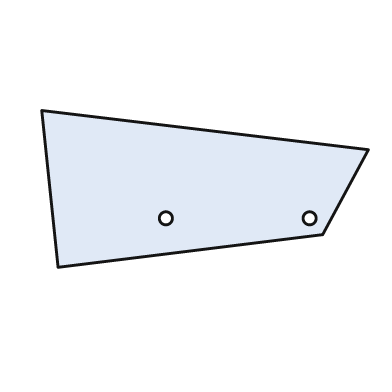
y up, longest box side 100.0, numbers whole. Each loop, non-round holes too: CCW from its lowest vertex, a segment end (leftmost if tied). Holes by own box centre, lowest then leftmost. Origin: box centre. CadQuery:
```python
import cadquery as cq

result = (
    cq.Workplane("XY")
    .moveTo(-45.0, -24.0)
    .lineTo(36.0, -14.0)
    .lineTo(50.0, 12.0)
    .lineTo(-50.0, 24.0)
    .close()
    .moveTo(-12.0, -9.0)
    .circle(2.0)
    .moveTo(32.0, -9.0)
    .circle(2.0)
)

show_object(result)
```